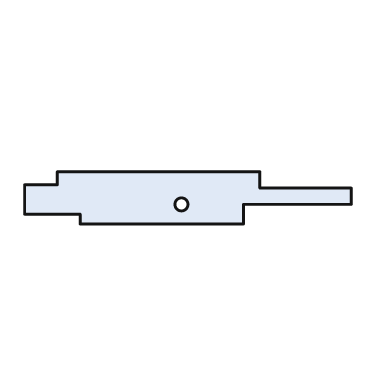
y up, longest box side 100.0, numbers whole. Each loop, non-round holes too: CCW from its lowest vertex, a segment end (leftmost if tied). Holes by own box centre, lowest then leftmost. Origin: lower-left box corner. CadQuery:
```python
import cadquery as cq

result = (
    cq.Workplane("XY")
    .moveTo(17.0, 0.0)
    .lineTo(67.0, 0.0)
    .lineTo(67.0, 6.0)
    .lineTo(100.0, 6.0)
    .lineTo(100.0, 11.0)
    .lineTo(72.0, 11.0)
    .lineTo(72.0, 16.0)
    .lineTo(10.0, 16.0)
    .lineTo(10.0, 12.0)
    .lineTo(0.0, 12.0)
    .lineTo(0.0, 3.0)
    .lineTo(17.0, 3.0)
    .close()
    .moveTo(48.0, 6.0)
    .circle(2.0)
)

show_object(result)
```